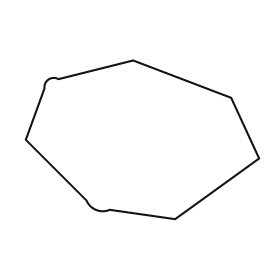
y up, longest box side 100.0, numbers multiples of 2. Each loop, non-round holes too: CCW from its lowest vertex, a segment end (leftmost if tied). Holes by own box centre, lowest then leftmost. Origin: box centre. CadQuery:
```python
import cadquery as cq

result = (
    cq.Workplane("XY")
    .moveTo(14.0, -34.0)
    .lineTo(50.0, -8.0)
    .lineTo(38.0, 18.0)
    .lineTo(-4.0, 34.0)
    .lineTo(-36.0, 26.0)
    .threePointArc((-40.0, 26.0), (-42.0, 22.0))
    .lineTo(-50.0, 0.0)
    .lineTo(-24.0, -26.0)
    .threePointArc((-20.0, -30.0), (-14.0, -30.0))
    .close()
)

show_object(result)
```